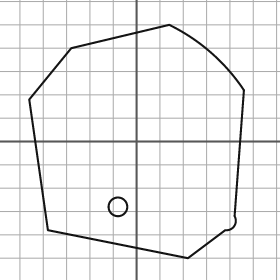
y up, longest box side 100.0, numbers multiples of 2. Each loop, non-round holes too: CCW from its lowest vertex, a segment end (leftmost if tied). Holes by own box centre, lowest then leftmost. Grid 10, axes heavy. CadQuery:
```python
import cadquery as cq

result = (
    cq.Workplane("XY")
    .moveTo(22.0, -50.0)
    .lineTo(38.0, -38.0)
    .threePointArc((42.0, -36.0), (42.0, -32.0))
    .lineTo(46.0, 22.0)
    .threePointArc((32.0, 38.0), (14.0, 50.0))
    .lineTo(-28.0, 40.0)
    .lineTo(-46.0, 18.0)
    .lineTo(-38.0, -38.0)
    .close()
    .moveTo(-8.0, -28.0)
    .circle(4.0)
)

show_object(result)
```